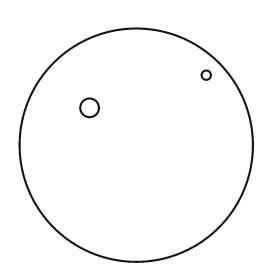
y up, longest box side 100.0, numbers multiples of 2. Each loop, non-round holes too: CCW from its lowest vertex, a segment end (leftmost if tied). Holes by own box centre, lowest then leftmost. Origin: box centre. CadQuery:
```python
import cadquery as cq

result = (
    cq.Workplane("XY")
    .moveTo(0.0, 0.0)
    .circle(50.0)
    .moveTo(-20.0, 16.0)
    .circle(4.0)
    .moveTo(30.0, 30.0)
    .circle(2.0)
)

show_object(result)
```